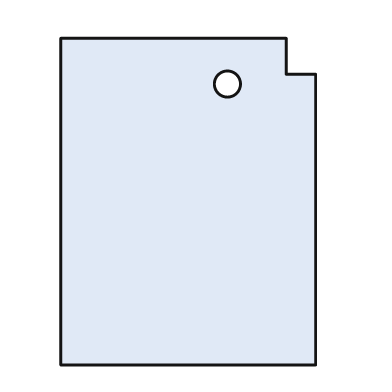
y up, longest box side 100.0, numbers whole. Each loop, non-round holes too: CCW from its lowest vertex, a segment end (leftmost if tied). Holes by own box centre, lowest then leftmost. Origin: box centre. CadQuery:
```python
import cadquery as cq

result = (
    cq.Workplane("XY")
    .moveTo(-39.0, -50.0)
    .lineTo(39.0, -50.0)
    .lineTo(39.0, 39.0)
    .lineTo(30.0, 39.0)
    .lineTo(30.0, 50.0)
    .lineTo(-39.0, 50.0)
    .close()
    .moveTo(12.0, 36.0)
    .circle(4.0)
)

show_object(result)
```